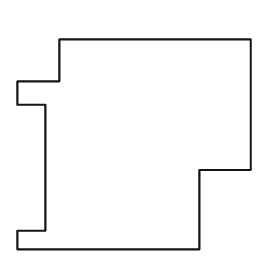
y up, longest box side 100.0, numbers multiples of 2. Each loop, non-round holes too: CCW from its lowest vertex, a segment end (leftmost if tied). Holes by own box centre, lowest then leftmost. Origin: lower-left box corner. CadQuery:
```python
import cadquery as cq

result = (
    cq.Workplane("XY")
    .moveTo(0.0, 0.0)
    .lineTo(78.0, 0.0)
    .lineTo(78.0, 34.0)
    .lineTo(100.0, 34.0)
    .lineTo(100.0, 90.0)
    .lineTo(18.0, 90.0)
    .lineTo(18.0, 72.0)
    .lineTo(0.0, 72.0)
    .lineTo(0.0, 62.0)
    .lineTo(12.0, 62.0)
    .lineTo(12.0, 8.0)
    .lineTo(0.0, 8.0)
    .close()
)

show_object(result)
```